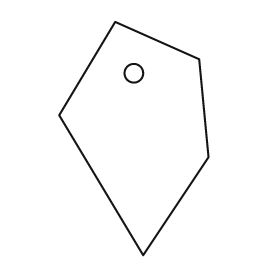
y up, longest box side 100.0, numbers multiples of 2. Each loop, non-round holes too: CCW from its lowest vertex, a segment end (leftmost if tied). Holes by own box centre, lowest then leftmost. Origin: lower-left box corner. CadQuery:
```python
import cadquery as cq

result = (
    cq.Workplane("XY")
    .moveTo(36.0, 0.0)
    .lineTo(64.0, 42.0)
    .lineTo(60.0, 84.0)
    .lineTo(24.0, 100.0)
    .lineTo(0.0, 60.0)
    .close()
    .moveTo(32.0, 78.0)
    .circle(4.0)
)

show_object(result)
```